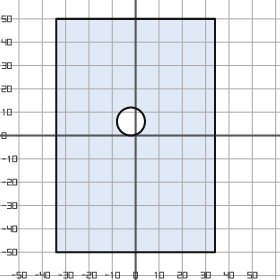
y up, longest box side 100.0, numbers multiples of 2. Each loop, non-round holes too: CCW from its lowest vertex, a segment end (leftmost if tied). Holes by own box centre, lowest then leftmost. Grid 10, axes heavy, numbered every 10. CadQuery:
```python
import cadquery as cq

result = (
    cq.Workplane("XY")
    .moveTo(-34.0, -50.0)
    .lineTo(34.0, -50.0)
    .lineTo(34.0, 50.0)
    .lineTo(-34.0, 50.0)
    .close()
    .moveTo(-2.0, 6.0)
    .circle(6.0)
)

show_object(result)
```